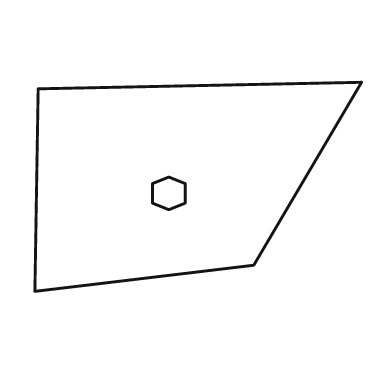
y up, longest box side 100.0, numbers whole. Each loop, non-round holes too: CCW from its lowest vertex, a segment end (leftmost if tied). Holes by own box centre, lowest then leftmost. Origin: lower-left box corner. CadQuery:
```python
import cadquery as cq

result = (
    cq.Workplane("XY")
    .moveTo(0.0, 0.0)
    .lineTo(67.0, 8.0)
    .lineTo(100.0, 64.0)
    .lineTo(1.0, 62.0)
    .close()
    .moveTo(41.0, 25.0)
    .lineTo(46.0, 27.0)
    .lineTo(46.0, 33.0)
    .lineTo(41.0, 35.0)
    .lineTo(36.0, 33.0)
    .lineTo(36.0, 27.0)
    .close()
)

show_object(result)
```